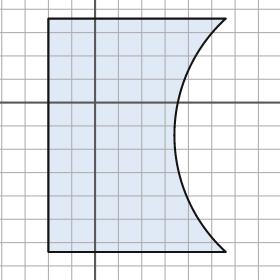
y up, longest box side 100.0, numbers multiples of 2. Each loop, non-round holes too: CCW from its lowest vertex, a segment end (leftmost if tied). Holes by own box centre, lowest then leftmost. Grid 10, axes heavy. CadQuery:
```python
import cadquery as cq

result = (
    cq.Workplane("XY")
    .moveTo(-20.0, -64.0)
    .lineTo(56.0, -64.0)
    .threePointArc((34.0, -14.0), (56.0, 36.0))
    .lineTo(-20.0, 36.0)
    .close()
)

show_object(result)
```